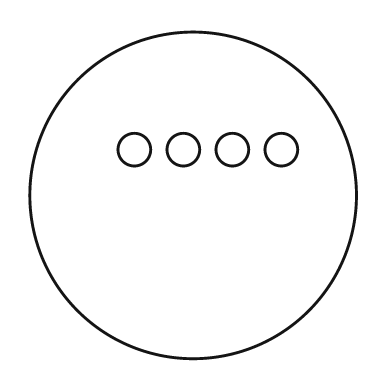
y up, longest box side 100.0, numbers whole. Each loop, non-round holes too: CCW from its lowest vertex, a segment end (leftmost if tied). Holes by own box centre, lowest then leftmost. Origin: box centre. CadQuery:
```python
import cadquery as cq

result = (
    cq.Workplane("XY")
    .moveTo(0.0, 0.0)
    .circle(50.0)
    .moveTo(-18.0, 14.0)
    .circle(5.0)
    .moveTo(-3.0, 14.0)
    .circle(5.0)
    .moveTo(12.0, 14.0)
    .circle(5.0)
    .moveTo(27.0, 14.0)
    .circle(5.0)
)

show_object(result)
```